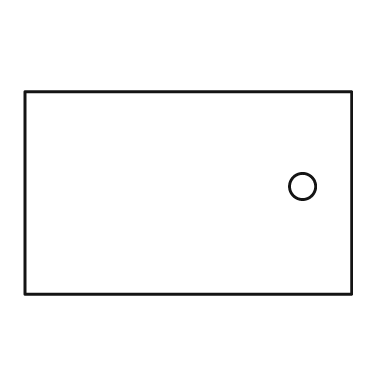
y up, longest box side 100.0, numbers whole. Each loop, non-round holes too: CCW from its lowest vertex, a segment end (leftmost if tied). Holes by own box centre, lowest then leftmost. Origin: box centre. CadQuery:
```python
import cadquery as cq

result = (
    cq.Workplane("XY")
    .moveTo(-50.0, -31.0)
    .lineTo(50.0, -31.0)
    .lineTo(50.0, 31.0)
    .lineTo(-50.0, 31.0)
    .close()
    .moveTo(35.0, 2.0)
    .circle(4.0)
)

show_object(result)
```